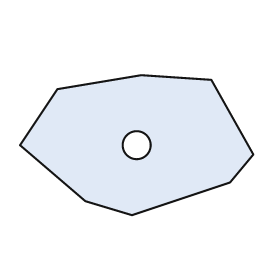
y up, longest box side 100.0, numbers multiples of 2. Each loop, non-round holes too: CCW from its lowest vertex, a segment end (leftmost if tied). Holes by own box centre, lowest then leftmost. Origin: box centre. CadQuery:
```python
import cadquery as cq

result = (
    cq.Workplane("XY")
    .moveTo(-2.0, -30.0)
    .lineTo(40.0, -16.0)
    .lineTo(50.0, -4.0)
    .lineTo(32.0, 28.0)
    .lineTo(2.0, 30.0)
    .lineTo(-34.0, 24.0)
    .lineTo(-50.0, 0.0)
    .lineTo(-22.0, -24.0)
    .close()
    .moveTo(0.0, 0.0)
    .circle(6.0)
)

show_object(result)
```